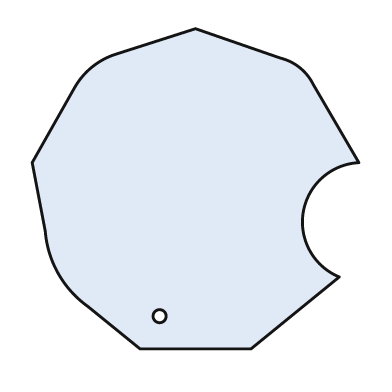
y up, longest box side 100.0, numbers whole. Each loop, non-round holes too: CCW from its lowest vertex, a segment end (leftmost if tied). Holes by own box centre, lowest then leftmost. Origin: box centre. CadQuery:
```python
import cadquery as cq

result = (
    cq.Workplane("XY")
    .moveTo(-17.0, -49.0)
    .lineTo(17.0, -49.0)
    .lineTo(44.0, -27.0)
    .threePointArc((33.0, -7.0), (50.0, 8.0))
    .lineTo(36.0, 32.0)
    .threePointArc((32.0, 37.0), (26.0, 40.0))
    .lineTo(0.0, 49.0)
    .lineTo(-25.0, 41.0)
    .threePointArc((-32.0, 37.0), (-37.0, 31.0))
    .lineTo(-50.0, 8.0)
    .lineTo(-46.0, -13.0)
    .threePointArc((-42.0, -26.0), (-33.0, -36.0))
    .close()
    .moveTo(-11.0, -39.0)
    .circle(2.0)
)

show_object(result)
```